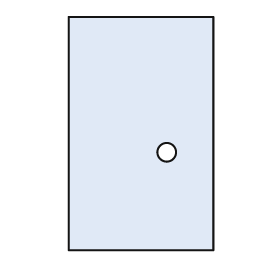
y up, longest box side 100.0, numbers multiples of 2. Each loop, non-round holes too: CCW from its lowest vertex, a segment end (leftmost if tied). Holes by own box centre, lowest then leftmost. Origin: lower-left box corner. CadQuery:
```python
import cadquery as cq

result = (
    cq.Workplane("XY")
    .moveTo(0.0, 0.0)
    .lineTo(62.0, 0.0)
    .lineTo(62.0, 100.0)
    .lineTo(0.0, 100.0)
    .close()
    .moveTo(42.0, 42.0)
    .circle(4.0)
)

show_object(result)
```